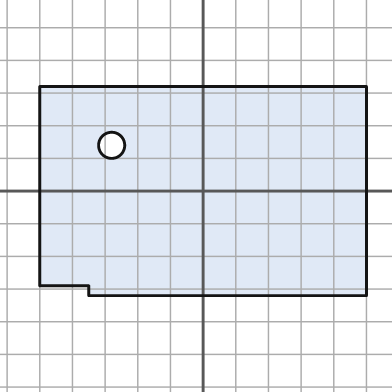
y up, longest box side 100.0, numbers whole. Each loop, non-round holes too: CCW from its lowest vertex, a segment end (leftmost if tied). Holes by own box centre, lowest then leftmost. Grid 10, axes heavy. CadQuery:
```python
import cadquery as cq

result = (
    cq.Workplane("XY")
    .moveTo(-35.0, -32.0)
    .lineTo(50.0, -32.0)
    .lineTo(50.0, 32.0)
    .lineTo(-50.0, 32.0)
    .lineTo(-50.0, -29.0)
    .lineTo(-35.0, -29.0)
    .close()
    .moveTo(-28.0, 14.0)
    .circle(4.0)
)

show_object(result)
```